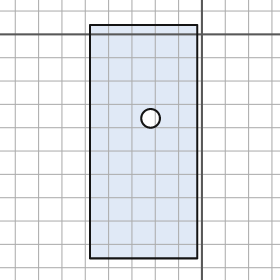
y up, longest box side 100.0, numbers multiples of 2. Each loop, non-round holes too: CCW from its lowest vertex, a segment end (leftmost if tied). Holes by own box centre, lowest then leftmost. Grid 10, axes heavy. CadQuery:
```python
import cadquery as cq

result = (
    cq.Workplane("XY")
    .moveTo(-48.0, -96.0)
    .lineTo(-2.0, -96.0)
    .lineTo(-2.0, 4.0)
    .lineTo(-48.0, 4.0)
    .close()
    .moveTo(-22.0, -36.0)
    .circle(4.0)
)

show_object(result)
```